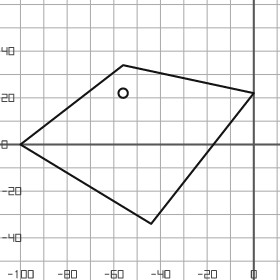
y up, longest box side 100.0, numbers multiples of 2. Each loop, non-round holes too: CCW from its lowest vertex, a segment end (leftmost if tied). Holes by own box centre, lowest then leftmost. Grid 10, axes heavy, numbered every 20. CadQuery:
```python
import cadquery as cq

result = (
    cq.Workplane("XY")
    .moveTo(-44.0, -34.0)
    .lineTo(0.0, 22.0)
    .lineTo(-56.0, 34.0)
    .lineTo(-100.0, 0.0)
    .close()
    .moveTo(-56.0, 22.0)
    .circle(2.0)
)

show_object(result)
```